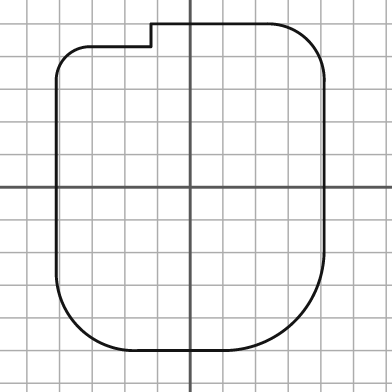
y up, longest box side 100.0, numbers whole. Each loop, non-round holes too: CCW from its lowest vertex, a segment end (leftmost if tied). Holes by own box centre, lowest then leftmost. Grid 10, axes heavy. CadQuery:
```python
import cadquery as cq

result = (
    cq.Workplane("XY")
    .moveTo(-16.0, -50.0)
    .lineTo(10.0, -50.0)
    .threePointArc((32.0, -41.0), (41.0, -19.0))
    .lineTo(41.0, 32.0)
    .threePointArc((36.0, 45.0), (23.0, 50.0))
    .lineTo(-12.0, 50.0)
    .lineTo(-12.0, 43.0)
    .lineTo(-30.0, 43.0)
    .threePointArc((-38.0, 40.0), (-41.0, 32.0))
    .lineTo(-41.0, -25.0)
    .threePointArc((-34.0, -43.0), (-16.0, -50.0))
    .close()
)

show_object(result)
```